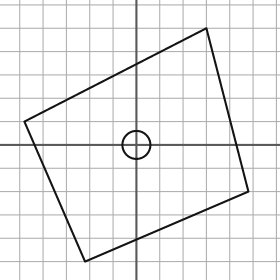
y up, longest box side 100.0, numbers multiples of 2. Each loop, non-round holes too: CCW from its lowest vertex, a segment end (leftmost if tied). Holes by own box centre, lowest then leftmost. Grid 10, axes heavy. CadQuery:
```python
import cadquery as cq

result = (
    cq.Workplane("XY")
    .moveTo(-22.0, -50.0)
    .lineTo(48.0, -20.0)
    .lineTo(30.0, 50.0)
    .lineTo(-48.0, 10.0)
    .close()
    .moveTo(0.0, 0.0)
    .circle(6.0)
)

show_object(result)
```